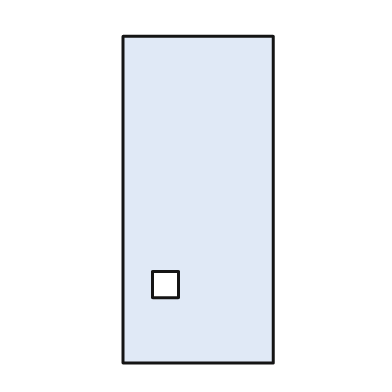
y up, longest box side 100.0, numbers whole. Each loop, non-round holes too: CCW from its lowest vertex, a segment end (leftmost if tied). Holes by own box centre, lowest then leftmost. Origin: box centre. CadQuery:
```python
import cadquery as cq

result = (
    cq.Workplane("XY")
    .moveTo(-23.0, -50.0)
    .lineTo(23.0, -50.0)
    .lineTo(23.0, 50.0)
    .lineTo(-23.0, 50.0)
    .close()
    .moveTo(-14.0, -30.0)
    .lineTo(-6.0, -30.0)
    .lineTo(-6.0, -22.0)
    .lineTo(-14.0, -22.0)
    .close()
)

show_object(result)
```